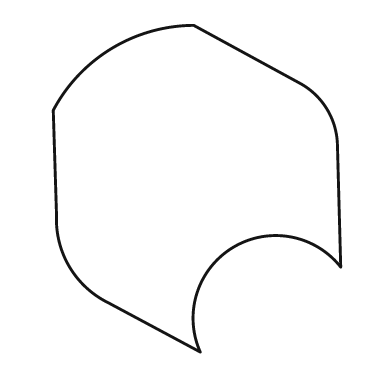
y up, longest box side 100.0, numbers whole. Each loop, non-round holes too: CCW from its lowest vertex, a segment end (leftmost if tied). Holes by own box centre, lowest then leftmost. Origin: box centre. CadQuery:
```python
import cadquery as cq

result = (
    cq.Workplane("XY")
    .moveTo(1.0, -50.0)
    .threePointArc((11.0, -18.0), (44.0, -24.0))
    .lineTo(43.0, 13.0)
    .threePointArc((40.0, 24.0), (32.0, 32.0))
    .lineTo(-1.0, 50.0)
    .threePointArc((-26.0, 43.0), (-44.0, 24.0))
    .lineTo(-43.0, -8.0)
    .threePointArc((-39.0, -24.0), (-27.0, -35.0))
    .close()
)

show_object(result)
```